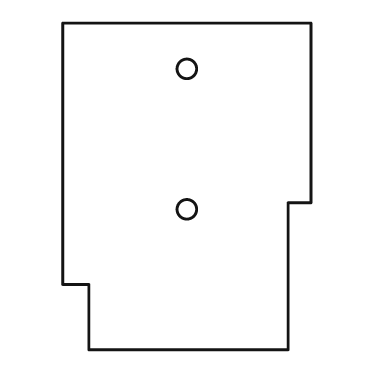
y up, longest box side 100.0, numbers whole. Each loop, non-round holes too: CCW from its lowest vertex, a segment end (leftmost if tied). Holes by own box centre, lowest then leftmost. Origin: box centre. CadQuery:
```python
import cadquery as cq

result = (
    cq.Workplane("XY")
    .moveTo(-30.0, -50.0)
    .lineTo(31.0, -50.0)
    .lineTo(31.0, -5.0)
    .lineTo(38.0, -5.0)
    .lineTo(38.0, 50.0)
    .lineTo(-38.0, 50.0)
    .lineTo(-38.0, -30.0)
    .lineTo(-30.0, -30.0)
    .close()
    .moveTo(0.0, -7.0)
    .circle(3.0)
    .moveTo(0.0, 36.0)
    .circle(3.0)
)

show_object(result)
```